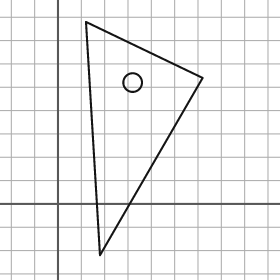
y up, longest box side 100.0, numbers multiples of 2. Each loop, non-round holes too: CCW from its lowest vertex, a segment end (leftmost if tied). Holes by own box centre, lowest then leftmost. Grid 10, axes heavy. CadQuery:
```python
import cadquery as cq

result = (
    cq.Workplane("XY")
    .moveTo(18.0, -22.0)
    .lineTo(62.0, 54.0)
    .lineTo(12.0, 78.0)
    .close()
    .moveTo(32.0, 52.0)
    .circle(4.0)
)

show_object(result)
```